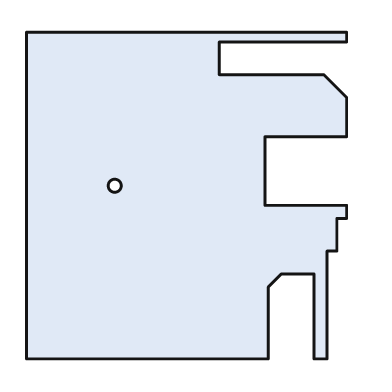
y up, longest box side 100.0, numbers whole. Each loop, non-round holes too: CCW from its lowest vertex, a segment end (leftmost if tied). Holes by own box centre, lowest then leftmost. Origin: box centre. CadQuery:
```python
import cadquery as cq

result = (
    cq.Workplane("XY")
    .moveTo(-49.0, -50.0)
    .lineTo(25.0, -50.0)
    .lineTo(25.0, -28.0)
    .lineTo(29.0, -24.0)
    .lineTo(39.0, -24.0)
    .lineTo(39.0, -50.0)
    .lineTo(43.0, -50.0)
    .lineTo(43.0, -17.0)
    .lineTo(46.0, -17.0)
    .lineTo(46.0, -7.0)
    .lineTo(49.0, -7.0)
    .lineTo(49.0, -3.0)
    .lineTo(24.0, -3.0)
    .lineTo(24.0, 18.0)
    .lineTo(49.0, 18.0)
    .lineTo(49.0, 30.0)
    .lineTo(42.0, 37.0)
    .lineTo(10.0, 37.0)
    .lineTo(10.0, 47.0)
    .lineTo(49.0, 47.0)
    .lineTo(49.0, 50.0)
    .lineTo(-49.0, 50.0)
    .close()
    .moveTo(-22.0, 3.0)
    .circle(2.0)
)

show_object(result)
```